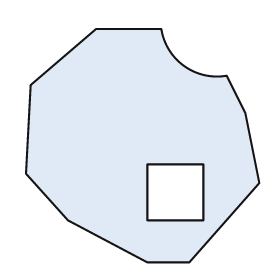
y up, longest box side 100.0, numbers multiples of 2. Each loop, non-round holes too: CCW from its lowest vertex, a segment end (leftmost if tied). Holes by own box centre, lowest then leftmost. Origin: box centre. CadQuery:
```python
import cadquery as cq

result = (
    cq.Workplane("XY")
    .moveTo(2.0, -50.0)
    .lineTo(20.0, -50.0)
    .lineTo(50.0, -16.0)
    .lineTo(44.0, 14.0)
    .lineTo(36.0, 30.0)
    .threePointArc((18.0, 34.0), (8.0, 50.0))
    .lineTo(-20.0, 50.0)
    .lineTo(-48.0, 26.0)
    .lineTo(-50.0, -12.0)
    .lineTo(-32.0, -32.0)
    .close()
    .moveTo(2.0, -32.0)
    .lineTo(26.0, -32.0)
    .lineTo(26.0, -8.0)
    .lineTo(2.0, -8.0)
    .close()
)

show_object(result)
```